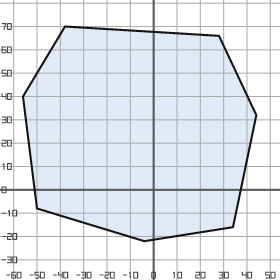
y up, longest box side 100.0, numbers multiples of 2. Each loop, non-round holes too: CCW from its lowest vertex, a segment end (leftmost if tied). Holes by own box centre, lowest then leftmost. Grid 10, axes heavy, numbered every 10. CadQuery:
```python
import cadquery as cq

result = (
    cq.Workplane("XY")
    .moveTo(-4.0, -22.0)
    .lineTo(34.0, -16.0)
    .lineTo(44.0, 32.0)
    .lineTo(28.0, 66.0)
    .lineTo(-38.0, 70.0)
    .lineTo(-56.0, 40.0)
    .lineTo(-50.0, -8.0)
    .close()
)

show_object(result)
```